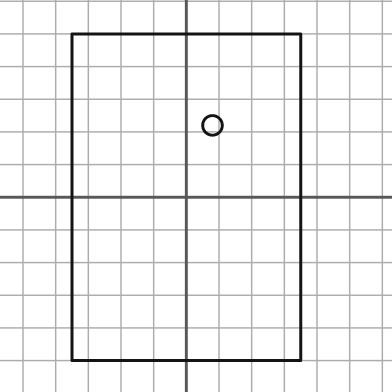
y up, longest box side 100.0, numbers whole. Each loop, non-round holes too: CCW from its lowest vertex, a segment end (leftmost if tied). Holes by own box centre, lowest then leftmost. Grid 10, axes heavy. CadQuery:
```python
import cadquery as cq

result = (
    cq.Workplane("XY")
    .moveTo(-35.0, -50.0)
    .lineTo(35.0, -50.0)
    .lineTo(35.0, 50.0)
    .lineTo(-35.0, 50.0)
    .close()
    .moveTo(8.0, 22.0)
    .circle(3.0)
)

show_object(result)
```